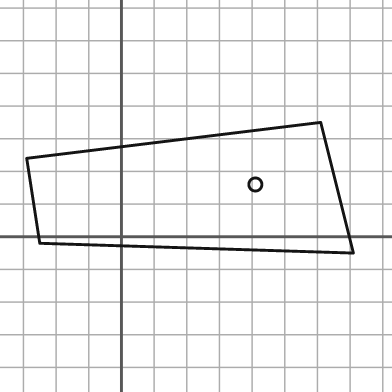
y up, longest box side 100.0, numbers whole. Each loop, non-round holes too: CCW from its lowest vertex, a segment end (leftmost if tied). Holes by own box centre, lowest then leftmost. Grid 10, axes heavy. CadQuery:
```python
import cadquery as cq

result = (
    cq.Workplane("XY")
    .moveTo(71.0, -5.0)
    .lineTo(61.0, 35.0)
    .lineTo(-29.0, 24.0)
    .lineTo(-25.0, -2.0)
    .close()
    .moveTo(41.0, 16.0)
    .circle(2.0)
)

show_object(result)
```